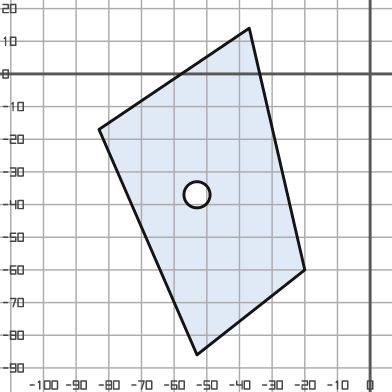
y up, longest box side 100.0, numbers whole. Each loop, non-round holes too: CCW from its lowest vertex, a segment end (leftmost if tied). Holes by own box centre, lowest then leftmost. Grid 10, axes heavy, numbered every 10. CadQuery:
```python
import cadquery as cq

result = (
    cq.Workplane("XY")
    .moveTo(-53.0, -86.0)
    .lineTo(-20.0, -60.0)
    .lineTo(-37.0, 14.0)
    .lineTo(-83.0, -17.0)
    .close()
    .moveTo(-53.0, -37.0)
    .circle(4.0)
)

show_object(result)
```